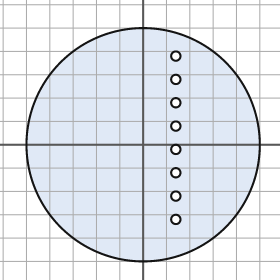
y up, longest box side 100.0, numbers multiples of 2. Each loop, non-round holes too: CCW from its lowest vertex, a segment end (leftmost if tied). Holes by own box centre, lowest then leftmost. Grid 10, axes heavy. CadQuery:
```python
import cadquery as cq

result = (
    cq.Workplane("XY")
    .moveTo(0.0, 0.0)
    .circle(50.0)
    .moveTo(14.0, -32.0)
    .circle(2.0)
    .moveTo(14.0, -22.0)
    .circle(2.0)
    .moveTo(14.0, -12.0)
    .circle(2.0)
    .moveTo(14.0, -2.0)
    .circle(2.0)
    .moveTo(14.0, 8.0)
    .circle(2.0)
    .moveTo(14.0, 18.0)
    .circle(2.0)
    .moveTo(14.0, 28.0)
    .circle(2.0)
    .moveTo(14.0, 38.0)
    .circle(2.0)
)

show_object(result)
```